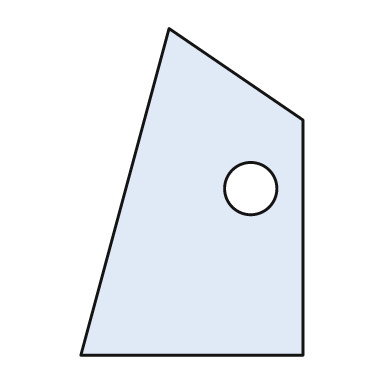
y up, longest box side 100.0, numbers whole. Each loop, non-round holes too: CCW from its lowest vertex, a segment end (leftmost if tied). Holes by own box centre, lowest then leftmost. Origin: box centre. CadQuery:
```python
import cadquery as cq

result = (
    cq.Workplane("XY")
    .moveTo(-34.0, -50.0)
    .lineTo(34.0, -50.0)
    .lineTo(34.0, 22.0)
    .lineTo(-7.0, 50.0)
    .close()
    .moveTo(18.0, 1.0)
    .circle(8.0)
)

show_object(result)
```